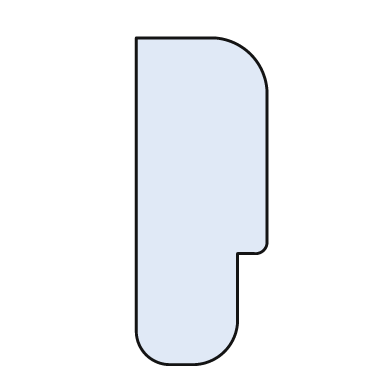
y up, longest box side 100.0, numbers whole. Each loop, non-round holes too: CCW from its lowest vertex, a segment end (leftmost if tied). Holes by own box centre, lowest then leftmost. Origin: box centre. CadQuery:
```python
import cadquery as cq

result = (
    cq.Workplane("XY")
    .moveTo(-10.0, -50.0)
    .lineTo(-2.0, -50.0)
    .threePointArc((7.0, -46.0), (11.0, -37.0))
    .lineTo(11.0, -16.0)
    .lineTo(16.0, -16.0)
    .threePointArc((19.0, -15.0), (20.0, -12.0))
    .lineTo(20.0, 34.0)
    .threePointArc((15.0, 45.0), (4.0, 50.0))
    .lineTo(-20.0, 50.0)
    .lineTo(-20.0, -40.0)
    .threePointArc((-17.0, -47.0), (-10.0, -50.0))
    .close()
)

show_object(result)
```